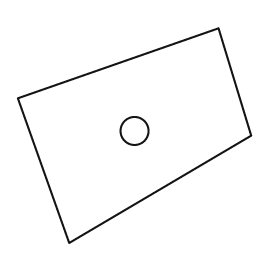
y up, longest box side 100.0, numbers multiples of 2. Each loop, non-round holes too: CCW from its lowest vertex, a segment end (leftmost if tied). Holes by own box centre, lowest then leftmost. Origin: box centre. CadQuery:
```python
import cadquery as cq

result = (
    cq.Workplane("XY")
    .moveTo(-28.0, -46.0)
    .lineTo(50.0, 0.0)
    .lineTo(36.0, 46.0)
    .lineTo(-50.0, 16.0)
    .close()
    .moveTo(0.0, 2.0)
    .circle(6.0)
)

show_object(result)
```